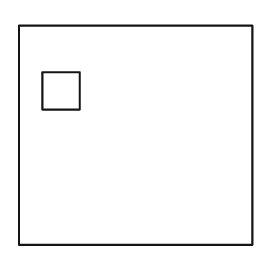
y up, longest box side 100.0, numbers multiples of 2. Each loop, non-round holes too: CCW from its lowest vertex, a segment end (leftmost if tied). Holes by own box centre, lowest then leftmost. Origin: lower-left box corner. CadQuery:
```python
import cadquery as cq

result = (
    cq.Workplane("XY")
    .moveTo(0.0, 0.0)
    .lineTo(100.0, 0.0)
    .lineTo(100.0, 94.0)
    .lineTo(0.0, 94.0)
    .close()
    .moveTo(10.0, 58.0)
    .lineTo(26.0, 58.0)
    .lineTo(26.0, 74.0)
    .lineTo(10.0, 74.0)
    .close()
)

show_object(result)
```